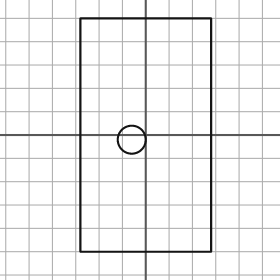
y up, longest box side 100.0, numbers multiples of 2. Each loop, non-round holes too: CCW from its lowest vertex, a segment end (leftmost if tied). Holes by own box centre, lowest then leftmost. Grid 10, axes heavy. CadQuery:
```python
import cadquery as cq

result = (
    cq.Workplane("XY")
    .moveTo(-28.0, -50.0)
    .lineTo(28.0, -50.0)
    .lineTo(28.0, 50.0)
    .lineTo(-28.0, 50.0)
    .close()
    .moveTo(-6.0, -2.0)
    .circle(6.0)
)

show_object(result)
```